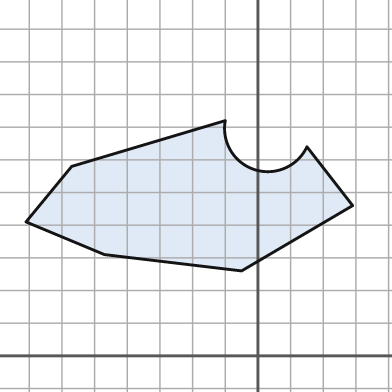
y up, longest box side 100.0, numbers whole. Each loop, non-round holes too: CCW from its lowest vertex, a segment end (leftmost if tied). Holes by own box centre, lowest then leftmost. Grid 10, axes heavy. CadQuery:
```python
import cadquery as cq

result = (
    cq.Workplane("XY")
    .moveTo(-5.0, 26.0)
    .lineTo(29.0, 46.0)
    .lineTo(15.0, 64.0)
    .threePointArc((-1.0, 57.0), (-10.0, 72.0))
    .lineTo(-57.0, 58.0)
    .lineTo(-71.0, 41.0)
    .lineTo(-47.0, 31.0)
    .close()
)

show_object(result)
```